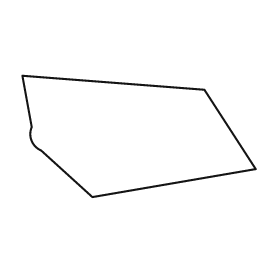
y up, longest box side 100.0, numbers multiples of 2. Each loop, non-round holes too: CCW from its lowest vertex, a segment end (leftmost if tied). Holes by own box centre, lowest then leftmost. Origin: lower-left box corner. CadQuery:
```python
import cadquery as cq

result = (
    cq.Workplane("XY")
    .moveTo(30.0, 0.0)
    .lineTo(100.0, 12.0)
    .lineTo(78.0, 46.0)
    .lineTo(0.0, 52.0)
    .lineTo(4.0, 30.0)
    .threePointArc((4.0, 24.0), (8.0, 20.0))
    .close()
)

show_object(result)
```